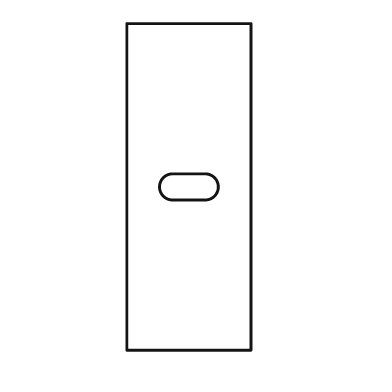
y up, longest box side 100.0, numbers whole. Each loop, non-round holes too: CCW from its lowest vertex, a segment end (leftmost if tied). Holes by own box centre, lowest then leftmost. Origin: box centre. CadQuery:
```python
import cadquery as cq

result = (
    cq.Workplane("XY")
    .moveTo(-19.0, -50.0)
    .lineTo(19.0, -50.0)
    .lineTo(19.0, 50.0)
    .lineTo(-19.0, 50.0)
    .close()
    .moveTo(-5.0, -4.0)
    .lineTo(5.0, -4.0)
    .threePointArc((9.0, 0.0), (5.0, 4.0))
    .lineTo(-5.0, 4.0)
    .threePointArc((-9.0, 0.0), (-5.0, -4.0))
    .close()
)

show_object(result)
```